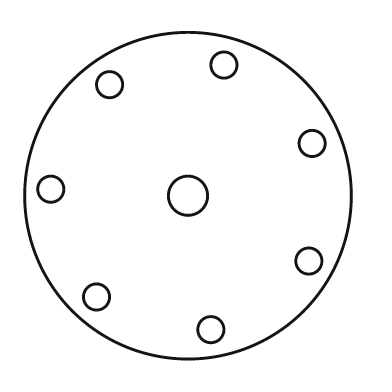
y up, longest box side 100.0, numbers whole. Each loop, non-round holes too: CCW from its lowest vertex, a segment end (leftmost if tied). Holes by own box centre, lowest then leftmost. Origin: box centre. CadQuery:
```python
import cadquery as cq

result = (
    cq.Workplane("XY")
    .moveTo(0.0, 0.0)
    .circle(50.0)
    .moveTo(7.0, -41.0)
    .circle(4.0)
    .moveTo(-28.0, -31.0)
    .circle(4.0)
    .moveTo(37.0, -20.0)
    .circle(4.0)
    .moveTo(0.0, 0.0)
    .circle(6.0)
    .moveTo(-42.0, 2.0)
    .circle(4.0)
    .moveTo(38.0, 16.0)
    .circle(4.0)
    .moveTo(-24.0, 34.0)
    .circle(4.0)
    .moveTo(11.0, 40.0)
    .circle(4.0)
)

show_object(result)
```